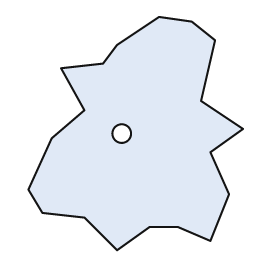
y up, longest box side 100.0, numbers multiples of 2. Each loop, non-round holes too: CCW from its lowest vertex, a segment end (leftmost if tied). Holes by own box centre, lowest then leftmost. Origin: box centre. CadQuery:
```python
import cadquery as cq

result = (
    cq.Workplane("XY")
    .moveTo(-8.0, -50.0)
    .lineTo(6.0, -40.0)
    .lineTo(18.0, -40.0)
    .lineTo(32.0, -46.0)
    .lineTo(40.0, -26.0)
    .lineTo(32.0, -8.0)
    .lineTo(46.0, 2.0)
    .lineTo(28.0, 14.0)
    .lineTo(34.0, 40.0)
    .lineTo(24.0, 48.0)
    .lineTo(10.0, 50.0)
    .lineTo(-8.0, 38.0)
    .lineTo(-14.0, 30.0)
    .lineTo(-32.0, 28.0)
    .lineTo(-22.0, 10.0)
    .lineTo(-36.0, -2.0)
    .lineTo(-46.0, -24.0)
    .lineTo(-40.0, -34.0)
    .lineTo(-22.0, -36.0)
    .close()
    .moveTo(-6.0, 0.0)
    .circle(4.0)
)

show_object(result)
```